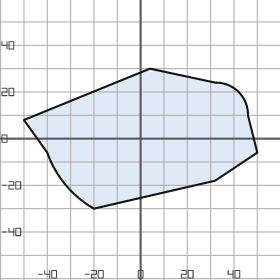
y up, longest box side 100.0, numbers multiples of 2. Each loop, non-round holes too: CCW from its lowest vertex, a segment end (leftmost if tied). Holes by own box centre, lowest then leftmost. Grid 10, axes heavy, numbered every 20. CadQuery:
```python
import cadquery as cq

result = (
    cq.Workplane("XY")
    .moveTo(-20.0, -30.0)
    .lineTo(32.0, -18.0)
    .lineTo(50.0, -6.0)
    .lineTo(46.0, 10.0)
    .threePointArc((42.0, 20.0), (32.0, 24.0))
    .lineTo(4.0, 30.0)
    .lineTo(-50.0, 8.0)
    .lineTo(-40.0, -6.0)
    .threePointArc((-32.0, -20.0), (-20.0, -30.0))
    .close()
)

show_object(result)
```